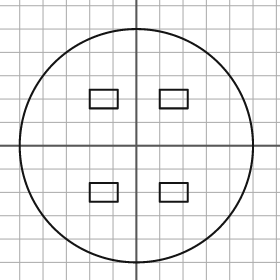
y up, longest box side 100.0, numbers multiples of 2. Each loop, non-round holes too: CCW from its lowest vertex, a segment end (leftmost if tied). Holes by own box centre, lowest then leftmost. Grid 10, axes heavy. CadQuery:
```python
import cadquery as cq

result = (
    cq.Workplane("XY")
    .moveTo(0.0, 0.0)
    .circle(50.0)
    .moveTo(-20.0, -24.0)
    .lineTo(-8.0, -24.0)
    .lineTo(-8.0, -16.0)
    .lineTo(-20.0, -16.0)
    .close()
    .moveTo(10.0, -24.0)
    .lineTo(22.0, -24.0)
    .lineTo(22.0, -16.0)
    .lineTo(10.0, -16.0)
    .close()
    .moveTo(-20.0, 16.0)
    .lineTo(-8.0, 16.0)
    .lineTo(-8.0, 24.0)
    .lineTo(-20.0, 24.0)
    .close()
    .moveTo(10.0, 16.0)
    .lineTo(22.0, 16.0)
    .lineTo(22.0, 24.0)
    .lineTo(10.0, 24.0)
    .close()
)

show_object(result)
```